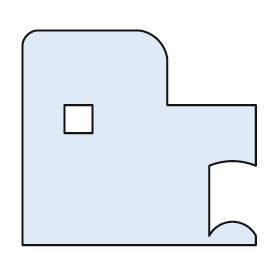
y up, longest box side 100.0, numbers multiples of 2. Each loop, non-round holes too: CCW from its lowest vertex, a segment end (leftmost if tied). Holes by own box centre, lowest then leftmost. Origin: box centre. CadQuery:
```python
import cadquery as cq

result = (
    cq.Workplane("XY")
    .moveTo(-50.0, -46.0)
    .lineTo(50.0, -46.0)
    .lineTo(50.0, -42.0)
    .threePointArc((40.0, -36.0), (30.0, -42.0))
    .lineTo(30.0, -12.0)
    .threePointArc((40.0, -10.0), (50.0, -12.0))
    .lineTo(50.0, 14.0)
    .lineTo(12.0, 14.0)
    .lineTo(12.0, 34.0)
    .threePointArc((8.0, 42.0), (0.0, 46.0))
    .lineTo(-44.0, 46.0)
    .threePointArc((-48.0, 44.0), (-50.0, 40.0))
    .close()
    .moveTo(-32.0, 2.0)
    .lineTo(-20.0, 2.0)
    .lineTo(-20.0, 14.0)
    .lineTo(-32.0, 14.0)
    .close()
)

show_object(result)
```